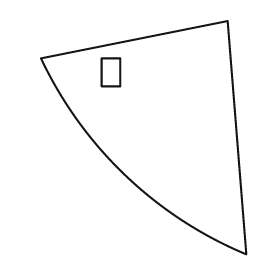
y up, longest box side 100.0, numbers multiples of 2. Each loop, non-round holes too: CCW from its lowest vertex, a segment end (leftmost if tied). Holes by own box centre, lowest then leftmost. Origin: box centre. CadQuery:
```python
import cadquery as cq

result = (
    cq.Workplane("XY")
    .moveTo(44.0, -50.0)
    .lineTo(36.0, 50.0)
    .lineTo(-44.0, 34.0)
    .threePointArc((-8.0, -16.0), (44.0, -50.0))
    .close()
    .moveTo(-18.0, 22.0)
    .lineTo(-10.0, 22.0)
    .lineTo(-10.0, 34.0)
    .lineTo(-18.0, 34.0)
    .close()
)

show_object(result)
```